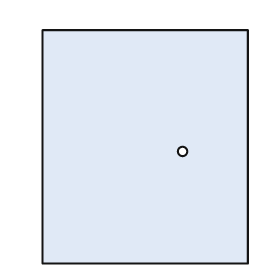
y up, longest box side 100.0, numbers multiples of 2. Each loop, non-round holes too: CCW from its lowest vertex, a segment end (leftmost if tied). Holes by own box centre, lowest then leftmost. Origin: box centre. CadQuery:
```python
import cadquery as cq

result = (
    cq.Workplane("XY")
    .moveTo(-44.0, -50.0)
    .lineTo(44.0, -50.0)
    .lineTo(44.0, 50.0)
    .lineTo(-44.0, 50.0)
    .close()
    .moveTo(16.0, -2.0)
    .circle(2.0)
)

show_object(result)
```